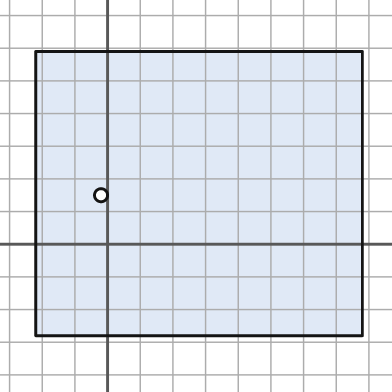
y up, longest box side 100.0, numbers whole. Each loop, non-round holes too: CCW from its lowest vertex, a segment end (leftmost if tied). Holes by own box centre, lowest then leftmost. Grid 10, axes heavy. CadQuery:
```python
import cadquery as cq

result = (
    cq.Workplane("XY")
    .moveTo(-22.0, -28.0)
    .lineTo(78.0, -28.0)
    .lineTo(78.0, 59.0)
    .lineTo(-22.0, 59.0)
    .close()
    .moveTo(-2.0, 15.0)
    .circle(2.0)
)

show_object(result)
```